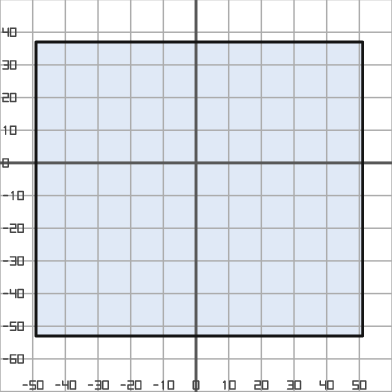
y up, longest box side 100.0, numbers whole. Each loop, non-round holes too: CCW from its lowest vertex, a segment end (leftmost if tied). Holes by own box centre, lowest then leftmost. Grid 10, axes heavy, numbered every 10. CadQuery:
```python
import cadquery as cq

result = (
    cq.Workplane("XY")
    .moveTo(-49.0, -53.0)
    .lineTo(51.0, -53.0)
    .lineTo(51.0, 37.0)
    .lineTo(-49.0, 37.0)
    .close()
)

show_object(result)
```